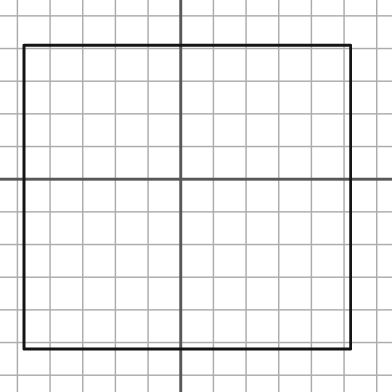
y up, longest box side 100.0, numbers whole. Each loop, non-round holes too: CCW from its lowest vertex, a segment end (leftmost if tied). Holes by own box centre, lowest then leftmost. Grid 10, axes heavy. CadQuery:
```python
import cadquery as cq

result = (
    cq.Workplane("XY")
    .moveTo(-48.0, -52.0)
    .lineTo(52.0, -52.0)
    .lineTo(52.0, 41.0)
    .lineTo(-48.0, 41.0)
    .close()
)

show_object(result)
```